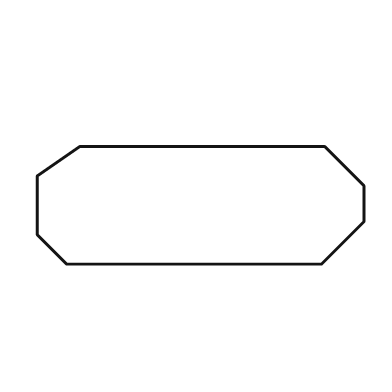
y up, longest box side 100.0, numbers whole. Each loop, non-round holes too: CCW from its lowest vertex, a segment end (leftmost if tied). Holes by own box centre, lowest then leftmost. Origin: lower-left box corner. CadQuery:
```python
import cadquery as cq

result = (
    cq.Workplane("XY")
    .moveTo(9.0, 0.0)
    .lineTo(87.0, 0.0)
    .lineTo(100.0, 13.0)
    .lineTo(100.0, 24.0)
    .lineTo(88.0, 36.0)
    .lineTo(13.0, 36.0)
    .lineTo(0.0, 27.0)
    .lineTo(0.0, 9.0)
    .close()
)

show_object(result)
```